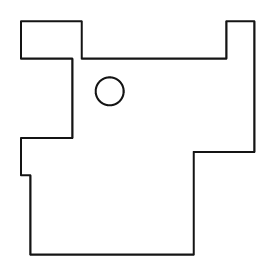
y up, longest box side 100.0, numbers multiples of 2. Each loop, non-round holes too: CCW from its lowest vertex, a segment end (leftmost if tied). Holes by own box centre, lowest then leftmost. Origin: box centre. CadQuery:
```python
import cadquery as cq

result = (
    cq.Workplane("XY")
    .moveTo(-46.0, -50.0)
    .lineTo(24.0, -50.0)
    .lineTo(24.0, -6.0)
    .lineTo(50.0, -6.0)
    .lineTo(50.0, 50.0)
    .lineTo(38.0, 50.0)
    .lineTo(38.0, 34.0)
    .lineTo(-24.0, 34.0)
    .lineTo(-24.0, 50.0)
    .lineTo(-50.0, 50.0)
    .lineTo(-50.0, 34.0)
    .lineTo(-28.0, 34.0)
    .lineTo(-28.0, 0.0)
    .lineTo(-50.0, 0.0)
    .lineTo(-50.0, -16.0)
    .lineTo(-46.0, -16.0)
    .close()
    .moveTo(-12.0, 20.0)
    .circle(6.0)
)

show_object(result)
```